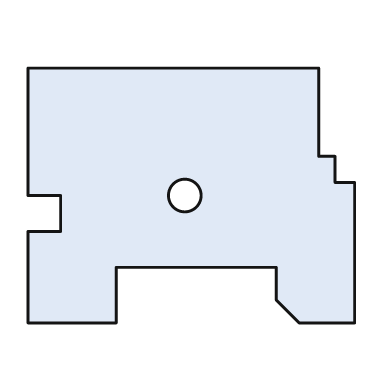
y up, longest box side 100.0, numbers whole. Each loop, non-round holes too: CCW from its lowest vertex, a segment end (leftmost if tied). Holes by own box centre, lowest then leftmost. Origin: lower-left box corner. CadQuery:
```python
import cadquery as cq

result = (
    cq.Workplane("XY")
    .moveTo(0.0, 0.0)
    .lineTo(27.0, 0.0)
    .lineTo(27.0, 17.0)
    .lineTo(76.0, 17.0)
    .lineTo(76.0, 7.0)
    .lineTo(83.0, 0.0)
    .lineTo(100.0, 0.0)
    .lineTo(100.0, 43.0)
    .lineTo(94.0, 43.0)
    .lineTo(94.0, 51.0)
    .lineTo(89.0, 51.0)
    .lineTo(89.0, 78.0)
    .lineTo(0.0, 78.0)
    .lineTo(0.0, 39.0)
    .lineTo(10.0, 39.0)
    .lineTo(10.0, 28.0)
    .lineTo(0.0, 28.0)
    .close()
    .moveTo(48.0, 39.0)
    .circle(5.0)
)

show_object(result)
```